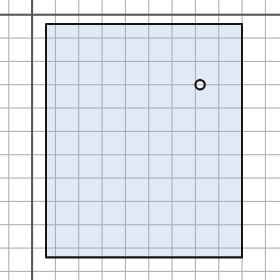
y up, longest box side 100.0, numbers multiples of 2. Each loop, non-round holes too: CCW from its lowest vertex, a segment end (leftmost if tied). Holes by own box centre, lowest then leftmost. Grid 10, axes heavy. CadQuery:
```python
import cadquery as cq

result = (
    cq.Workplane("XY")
    .moveTo(6.0, -104.0)
    .lineTo(90.0, -104.0)
    .lineTo(90.0, -4.0)
    .lineTo(6.0, -4.0)
    .close()
    .moveTo(72.0, -30.0)
    .circle(2.0)
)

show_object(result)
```